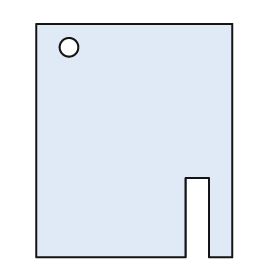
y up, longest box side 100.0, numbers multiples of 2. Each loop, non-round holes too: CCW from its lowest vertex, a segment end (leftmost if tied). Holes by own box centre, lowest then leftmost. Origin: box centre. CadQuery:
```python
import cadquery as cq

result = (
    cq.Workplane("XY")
    .moveTo(-42.0, -50.0)
    .lineTo(22.0, -50.0)
    .lineTo(22.0, -16.0)
    .lineTo(32.0, -16.0)
    .lineTo(32.0, -50.0)
    .lineTo(42.0, -50.0)
    .lineTo(42.0, 50.0)
    .lineTo(-42.0, 50.0)
    .close()
    .moveTo(-28.0, 40.0)
    .circle(4.0)
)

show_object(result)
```